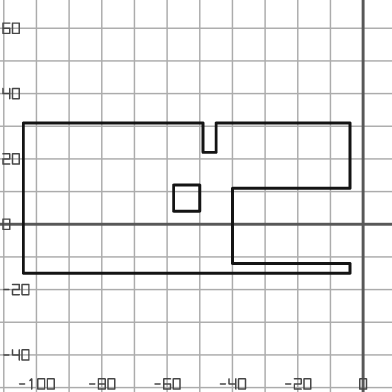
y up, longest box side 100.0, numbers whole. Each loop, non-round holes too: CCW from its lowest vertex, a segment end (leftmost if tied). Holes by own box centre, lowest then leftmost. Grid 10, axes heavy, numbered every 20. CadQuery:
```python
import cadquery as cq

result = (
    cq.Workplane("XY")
    .moveTo(-104.0, -15.0)
    .lineTo(-4.0, -15.0)
    .lineTo(-4.0, -12.0)
    .lineTo(-40.0, -12.0)
    .lineTo(-40.0, 11.0)
    .lineTo(-4.0, 11.0)
    .lineTo(-4.0, 31.0)
    .lineTo(-45.0, 31.0)
    .lineTo(-45.0, 22.0)
    .lineTo(-49.0, 22.0)
    .lineTo(-49.0, 31.0)
    .lineTo(-104.0, 31.0)
    .close()
    .moveTo(-58.0, 4.0)
    .lineTo(-50.0, 4.0)
    .lineTo(-50.0, 12.0)
    .lineTo(-58.0, 12.0)
    .close()
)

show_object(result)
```